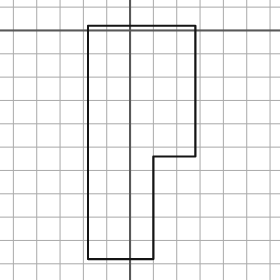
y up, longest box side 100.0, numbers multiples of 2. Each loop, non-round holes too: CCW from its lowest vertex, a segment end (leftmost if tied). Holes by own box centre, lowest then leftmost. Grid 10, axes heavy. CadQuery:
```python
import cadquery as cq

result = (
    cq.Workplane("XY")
    .moveTo(-18.0, -98.0)
    .lineTo(10.0, -98.0)
    .lineTo(10.0, -54.0)
    .lineTo(28.0, -54.0)
    .lineTo(28.0, 2.0)
    .lineTo(-18.0, 2.0)
    .close()
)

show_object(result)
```